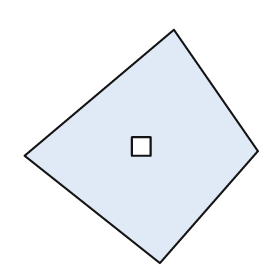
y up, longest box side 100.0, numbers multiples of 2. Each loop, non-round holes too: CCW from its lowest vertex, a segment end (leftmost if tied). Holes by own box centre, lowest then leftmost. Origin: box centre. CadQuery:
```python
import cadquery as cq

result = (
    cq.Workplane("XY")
    .moveTo(8.0, -50.0)
    .lineTo(50.0, -2.0)
    .lineTo(14.0, 50.0)
    .lineTo(-50.0, -4.0)
    .close()
    .moveTo(-4.0, -4.0)
    .lineTo(4.0, -4.0)
    .lineTo(4.0, 4.0)
    .lineTo(-4.0, 4.0)
    .close()
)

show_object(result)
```